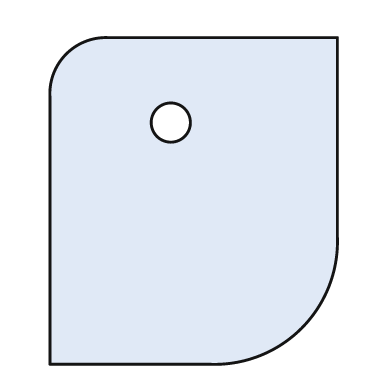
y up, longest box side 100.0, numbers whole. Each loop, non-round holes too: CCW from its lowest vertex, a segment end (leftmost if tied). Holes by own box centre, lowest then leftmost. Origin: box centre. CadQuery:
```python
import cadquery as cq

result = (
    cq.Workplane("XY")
    .moveTo(-44.0, -50.0)
    .lineTo(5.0, -50.0)
    .threePointArc((33.0, -39.0), (44.0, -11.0))
    .lineTo(44.0, 50.0)
    .lineTo(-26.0, 50.0)
    .threePointArc((-39.0, 45.0), (-44.0, 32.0))
    .close()
    .moveTo(-7.0, 24.0)
    .circle(6.0)
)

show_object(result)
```